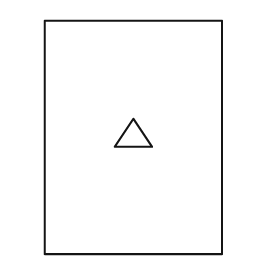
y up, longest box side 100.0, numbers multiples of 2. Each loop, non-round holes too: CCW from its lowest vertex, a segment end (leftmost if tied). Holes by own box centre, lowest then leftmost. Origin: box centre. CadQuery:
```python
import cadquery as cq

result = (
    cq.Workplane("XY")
    .moveTo(-38.0, -50.0)
    .lineTo(38.0, -50.0)
    .lineTo(38.0, 50.0)
    .lineTo(-38.0, 50.0)
    .close()
    .moveTo(-8.0, -4.0)
    .lineTo(8.0, -4.0)
    .lineTo(0.0, 8.0)
    .close()
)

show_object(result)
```